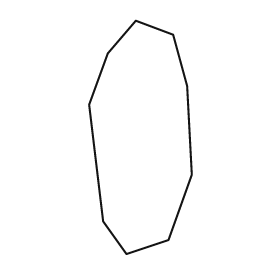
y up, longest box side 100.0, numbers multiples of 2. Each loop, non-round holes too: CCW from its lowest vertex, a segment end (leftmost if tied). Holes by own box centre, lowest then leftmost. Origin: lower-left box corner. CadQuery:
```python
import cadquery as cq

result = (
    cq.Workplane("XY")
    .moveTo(16.0, 0.0)
    .lineTo(34.0, 6.0)
    .lineTo(44.0, 34.0)
    .lineTo(42.0, 72.0)
    .lineTo(36.0, 94.0)
    .lineTo(20.0, 100.0)
    .lineTo(8.0, 86.0)
    .lineTo(0.0, 64.0)
    .lineTo(6.0, 14.0)
    .close()
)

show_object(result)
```